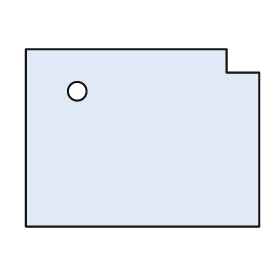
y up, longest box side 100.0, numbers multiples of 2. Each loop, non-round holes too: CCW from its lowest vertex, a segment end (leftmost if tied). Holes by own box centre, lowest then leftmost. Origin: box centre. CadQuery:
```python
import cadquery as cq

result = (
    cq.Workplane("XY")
    .moveTo(-50.0, -38.0)
    .lineTo(50.0, -38.0)
    .lineTo(50.0, 28.0)
    .lineTo(36.0, 28.0)
    .lineTo(36.0, 38.0)
    .lineTo(-50.0, 38.0)
    .close()
    .moveTo(-28.0, 20.0)
    .circle(4.0)
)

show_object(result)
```